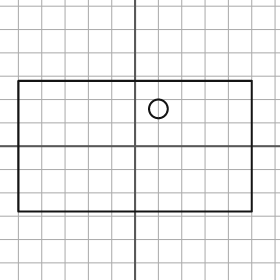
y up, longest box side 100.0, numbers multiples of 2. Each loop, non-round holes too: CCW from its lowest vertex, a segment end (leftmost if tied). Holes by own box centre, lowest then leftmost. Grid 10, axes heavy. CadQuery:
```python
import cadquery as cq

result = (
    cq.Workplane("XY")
    .moveTo(-50.0, -28.0)
    .lineTo(50.0, -28.0)
    .lineTo(50.0, 28.0)
    .lineTo(-50.0, 28.0)
    .close()
    .moveTo(10.0, 16.0)
    .circle(4.0)
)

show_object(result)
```